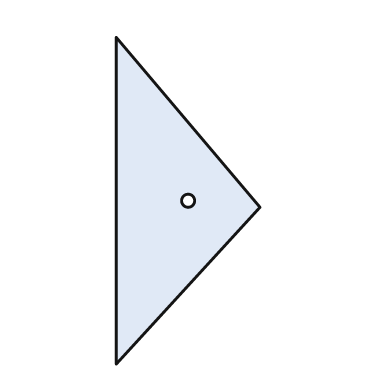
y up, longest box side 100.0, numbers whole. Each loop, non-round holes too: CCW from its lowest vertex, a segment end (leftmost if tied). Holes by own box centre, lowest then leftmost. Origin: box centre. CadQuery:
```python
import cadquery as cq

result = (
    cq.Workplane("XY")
    .moveTo(-22.0, -50.0)
    .lineTo(22.0, -2.0)
    .lineTo(-22.0, 50.0)
    .close()
    .moveTo(0.0, 0.0)
    .circle(2.0)
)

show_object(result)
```